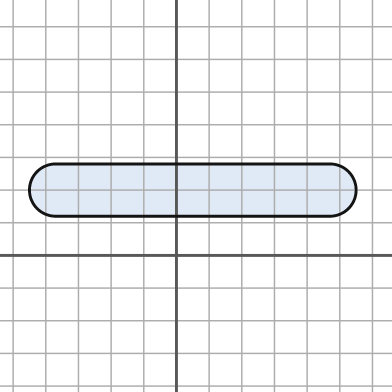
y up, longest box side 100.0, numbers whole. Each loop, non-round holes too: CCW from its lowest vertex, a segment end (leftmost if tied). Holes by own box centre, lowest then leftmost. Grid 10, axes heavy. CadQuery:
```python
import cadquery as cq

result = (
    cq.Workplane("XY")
    .moveTo(-37.0, 12.0)
    .lineTo(47.0, 12.0)
    .threePointArc((55.0, 20.0), (47.0, 28.0))
    .lineTo(-37.0, 28.0)
    .threePointArc((-45.0, 20.0), (-37.0, 12.0))
    .close()
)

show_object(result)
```